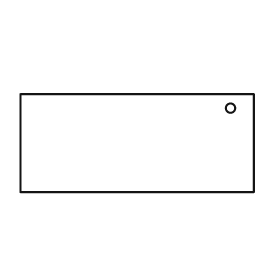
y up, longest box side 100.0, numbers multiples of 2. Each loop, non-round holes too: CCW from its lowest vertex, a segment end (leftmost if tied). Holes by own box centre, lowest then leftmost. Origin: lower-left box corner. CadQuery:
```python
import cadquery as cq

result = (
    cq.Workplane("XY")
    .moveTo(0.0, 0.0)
    .lineTo(100.0, 0.0)
    .lineTo(100.0, 42.0)
    .lineTo(0.0, 42.0)
    .close()
    .moveTo(90.0, 36.0)
    .circle(2.0)
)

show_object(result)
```